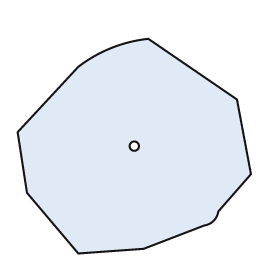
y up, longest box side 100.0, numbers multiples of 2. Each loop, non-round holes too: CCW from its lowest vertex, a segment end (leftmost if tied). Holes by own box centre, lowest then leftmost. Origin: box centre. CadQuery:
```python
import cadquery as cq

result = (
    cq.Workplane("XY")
    .moveTo(-24.0, -46.0)
    .lineTo(4.0, -44.0)
    .lineTo(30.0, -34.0)
    .threePointArc((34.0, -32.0), (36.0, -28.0))
    .lineTo(50.0, -12.0)
    .lineTo(44.0, 20.0)
    .lineTo(6.0, 46.0)
    .threePointArc((-10.0, 42.0), (-24.0, 34.0))
    .lineTo(-50.0, 6.0)
    .lineTo(-46.0, -20.0)
    .close()
    .moveTo(0.0, 0.0)
    .circle(2.0)
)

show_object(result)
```